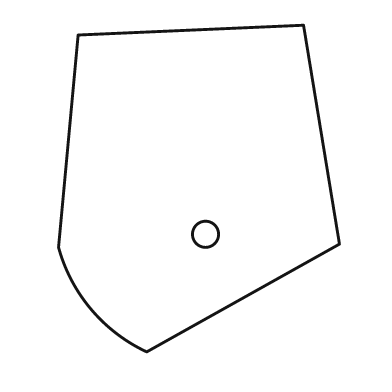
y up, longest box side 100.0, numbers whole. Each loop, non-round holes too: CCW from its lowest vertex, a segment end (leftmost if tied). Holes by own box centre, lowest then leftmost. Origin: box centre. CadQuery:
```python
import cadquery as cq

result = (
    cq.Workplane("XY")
    .moveTo(-16.0, -50.0)
    .lineTo(43.0, -17.0)
    .lineTo(32.0, 50.0)
    .lineTo(-37.0, 47.0)
    .lineTo(-43.0, -18.0)
    .threePointArc((-33.0, -37.0), (-16.0, -50.0))
    .close()
    .moveTo(2.0, -14.0)
    .circle(4.0)
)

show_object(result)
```